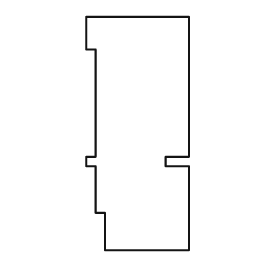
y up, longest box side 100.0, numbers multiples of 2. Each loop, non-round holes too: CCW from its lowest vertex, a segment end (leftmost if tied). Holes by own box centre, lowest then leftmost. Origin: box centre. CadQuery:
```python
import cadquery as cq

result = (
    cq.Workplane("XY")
    .moveTo(-14.0, -50.0)
    .lineTo(22.0, -50.0)
    .lineTo(22.0, -14.0)
    .lineTo(12.0, -14.0)
    .lineTo(12.0, -10.0)
    .lineTo(22.0, -10.0)
    .lineTo(22.0, 50.0)
    .lineTo(-22.0, 50.0)
    .lineTo(-22.0, 36.0)
    .lineTo(-18.0, 36.0)
    .lineTo(-18.0, -10.0)
    .lineTo(-22.0, -10.0)
    .lineTo(-22.0, -14.0)
    .lineTo(-18.0, -14.0)
    .lineTo(-18.0, -34.0)
    .lineTo(-14.0, -34.0)
    .close()
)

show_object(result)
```